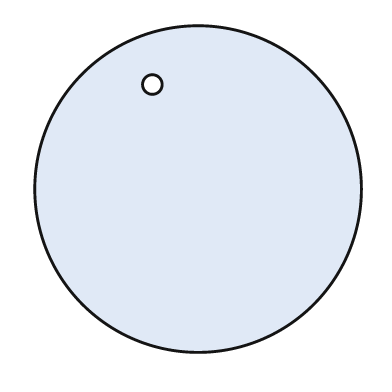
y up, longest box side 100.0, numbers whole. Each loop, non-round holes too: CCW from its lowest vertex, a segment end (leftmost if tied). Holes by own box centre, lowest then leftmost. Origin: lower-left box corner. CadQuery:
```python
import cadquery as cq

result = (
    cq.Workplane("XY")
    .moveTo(50.0, 50.0)
    .circle(50.0)
    .moveTo(36.0, 82.0)
    .circle(3.0)
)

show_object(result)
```